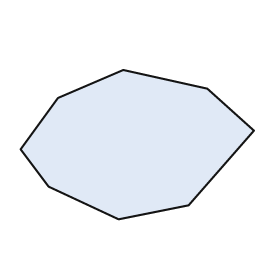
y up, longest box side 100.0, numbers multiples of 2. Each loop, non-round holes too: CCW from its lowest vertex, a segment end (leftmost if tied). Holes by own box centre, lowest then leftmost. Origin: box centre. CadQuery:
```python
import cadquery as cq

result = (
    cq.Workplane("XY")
    .moveTo(-8.0, -32.0)
    .lineTo(22.0, -26.0)
    .lineTo(50.0, 6.0)
    .lineTo(30.0, 24.0)
    .lineTo(-6.0, 32.0)
    .lineTo(-34.0, 20.0)
    .lineTo(-50.0, -2.0)
    .lineTo(-38.0, -18.0)
    .close()
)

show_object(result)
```